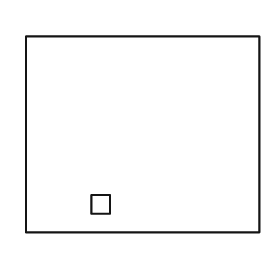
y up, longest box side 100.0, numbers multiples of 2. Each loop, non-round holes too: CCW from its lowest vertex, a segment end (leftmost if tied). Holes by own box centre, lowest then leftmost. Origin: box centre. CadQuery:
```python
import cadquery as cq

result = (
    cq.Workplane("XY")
    .moveTo(-50.0, -42.0)
    .lineTo(50.0, -42.0)
    .lineTo(50.0, 42.0)
    .lineTo(-50.0, 42.0)
    .close()
    .moveTo(-22.0, -34.0)
    .lineTo(-14.0, -34.0)
    .lineTo(-14.0, -26.0)
    .lineTo(-22.0, -26.0)
    .close()
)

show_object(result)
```